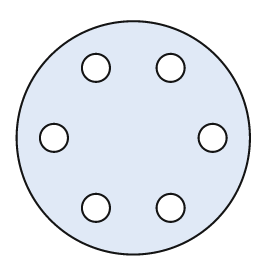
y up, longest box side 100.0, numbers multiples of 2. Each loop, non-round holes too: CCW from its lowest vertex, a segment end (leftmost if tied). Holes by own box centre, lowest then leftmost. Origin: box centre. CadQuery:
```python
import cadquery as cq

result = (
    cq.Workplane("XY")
    .moveTo(0.0, 0.0)
    .circle(50.0)
    .moveTo(-16.0, -30.0)
    .circle(6.0)
    .moveTo(16.0, -30.0)
    .circle(6.0)
    .moveTo(-34.0, 0.0)
    .circle(6.0)
    .moveTo(34.0, 0.0)
    .circle(6.0)
    .moveTo(-16.0, 30.0)
    .circle(6.0)
    .moveTo(16.0, 30.0)
    .circle(6.0)
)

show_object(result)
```